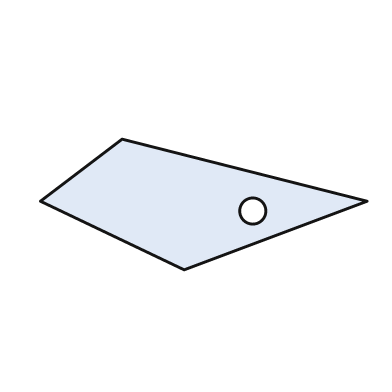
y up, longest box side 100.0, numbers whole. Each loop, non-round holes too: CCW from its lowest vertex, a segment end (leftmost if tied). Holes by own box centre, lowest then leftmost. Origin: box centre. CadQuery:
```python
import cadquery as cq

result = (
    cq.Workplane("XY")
    .moveTo(-6.0, -20.0)
    .lineTo(50.0, 1.0)
    .lineTo(-25.0, 20.0)
    .lineTo(-50.0, 1.0)
    .close()
    .moveTo(15.0, -2.0)
    .circle(4.0)
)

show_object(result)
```